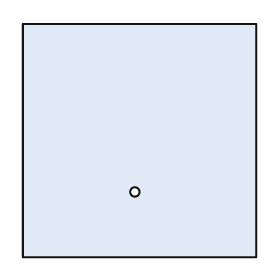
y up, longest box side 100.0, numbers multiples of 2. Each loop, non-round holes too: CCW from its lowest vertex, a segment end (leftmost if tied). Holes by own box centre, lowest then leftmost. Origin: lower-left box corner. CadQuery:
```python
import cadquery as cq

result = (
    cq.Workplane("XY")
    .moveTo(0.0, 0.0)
    .lineTo(100.0, 0.0)
    .lineTo(100.0, 100.0)
    .lineTo(0.0, 100.0)
    .close()
    .moveTo(48.0, 28.0)
    .circle(2.0)
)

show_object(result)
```